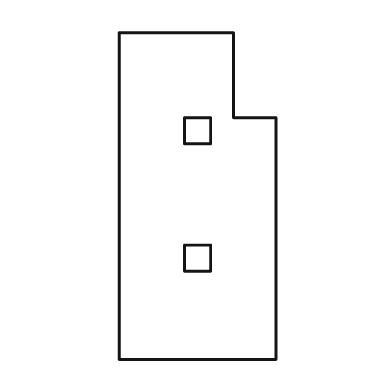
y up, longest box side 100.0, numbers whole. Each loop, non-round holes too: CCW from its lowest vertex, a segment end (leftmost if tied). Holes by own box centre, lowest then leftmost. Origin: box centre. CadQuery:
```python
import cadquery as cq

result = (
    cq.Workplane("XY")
    .moveTo(-24.0, -50.0)
    .lineTo(24.0, -50.0)
    .lineTo(24.0, 24.0)
    .lineTo(11.0, 24.0)
    .lineTo(11.0, 50.0)
    .lineTo(-24.0, 50.0)
    .close()
    .moveTo(-4.0, -23.0)
    .lineTo(4.0, -23.0)
    .lineTo(4.0, -15.0)
    .lineTo(-4.0, -15.0)
    .close()
    .moveTo(-4.0, 16.0)
    .lineTo(4.0, 16.0)
    .lineTo(4.0, 24.0)
    .lineTo(-4.0, 24.0)
    .close()
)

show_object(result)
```